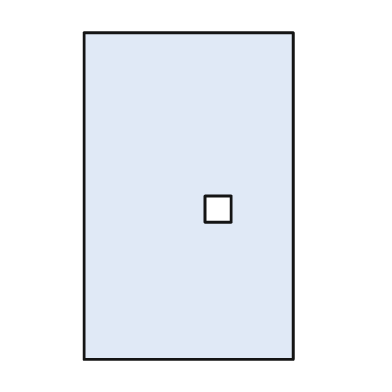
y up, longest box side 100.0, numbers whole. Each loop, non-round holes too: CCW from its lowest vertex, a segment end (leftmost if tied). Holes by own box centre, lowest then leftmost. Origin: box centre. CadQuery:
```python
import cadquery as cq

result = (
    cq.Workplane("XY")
    .moveTo(-32.0, -50.0)
    .lineTo(32.0, -50.0)
    .lineTo(32.0, 50.0)
    .lineTo(-32.0, 50.0)
    .close()
    .moveTo(5.0, -8.0)
    .lineTo(13.0, -8.0)
    .lineTo(13.0, 0.0)
    .lineTo(5.0, 0.0)
    .close()
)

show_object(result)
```